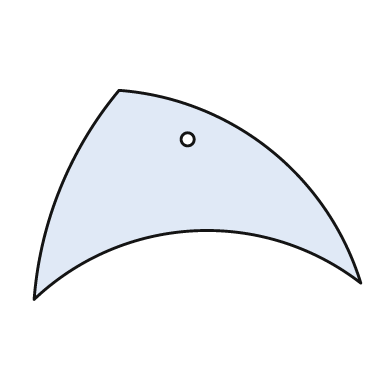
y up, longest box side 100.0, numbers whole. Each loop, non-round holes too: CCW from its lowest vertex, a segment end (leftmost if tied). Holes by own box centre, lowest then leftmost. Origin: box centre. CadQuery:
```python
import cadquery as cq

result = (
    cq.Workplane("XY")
    .moveTo(-50.0, -32.0)
    .threePointArc((-1.0, -11.0), (50.0, -27.0))
    .threePointArc((22.0, 14.0), (-24.0, 32.0))
    .threePointArc((-42.0, 2.0), (-50.0, -32.0))
    .close()
    .moveTo(-3.0, 17.0)
    .circle(2.0)
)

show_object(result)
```